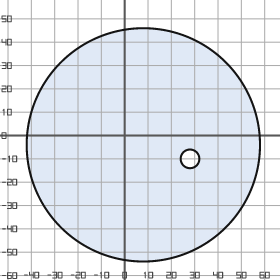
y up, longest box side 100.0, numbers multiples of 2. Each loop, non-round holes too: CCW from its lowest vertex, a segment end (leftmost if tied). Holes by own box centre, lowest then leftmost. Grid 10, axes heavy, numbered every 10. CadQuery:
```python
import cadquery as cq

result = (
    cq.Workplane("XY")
    .moveTo(8.0, -4.0)
    .circle(50.0)
    .moveTo(28.0, -10.0)
    .circle(4.0)
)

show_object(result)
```